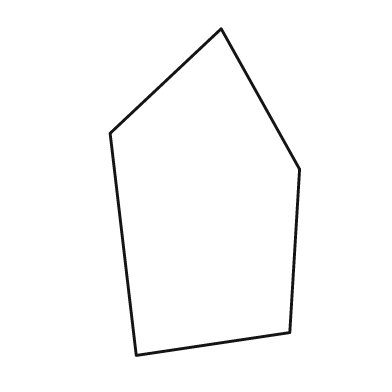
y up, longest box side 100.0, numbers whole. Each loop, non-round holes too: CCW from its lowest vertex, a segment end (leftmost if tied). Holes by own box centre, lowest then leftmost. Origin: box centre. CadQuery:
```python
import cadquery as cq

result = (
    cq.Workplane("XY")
    .moveTo(-21.0, -50.0)
    .lineTo(26.0, -43.0)
    .lineTo(29.0, 7.0)
    .lineTo(5.0, 50.0)
    .lineTo(-29.0, 18.0)
    .close()
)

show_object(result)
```